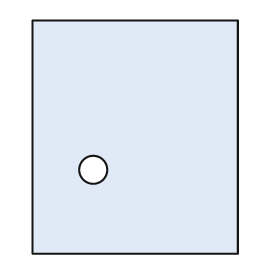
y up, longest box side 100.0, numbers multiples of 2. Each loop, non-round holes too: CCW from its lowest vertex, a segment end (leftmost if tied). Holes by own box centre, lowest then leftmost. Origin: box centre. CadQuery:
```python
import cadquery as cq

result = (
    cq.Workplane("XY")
    .moveTo(-44.0, -50.0)
    .lineTo(44.0, -50.0)
    .lineTo(44.0, 50.0)
    .lineTo(-44.0, 50.0)
    .close()
    .moveTo(-18.0, -14.0)
    .circle(6.0)
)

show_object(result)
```